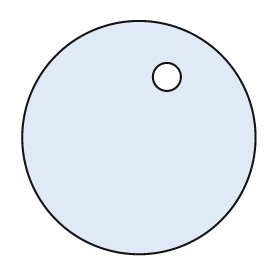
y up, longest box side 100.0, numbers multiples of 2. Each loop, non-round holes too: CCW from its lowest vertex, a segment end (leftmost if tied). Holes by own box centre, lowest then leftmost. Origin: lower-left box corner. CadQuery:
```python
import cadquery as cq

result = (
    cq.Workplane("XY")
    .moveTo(50.0, 50.0)
    .circle(50.0)
    .moveTo(62.0, 76.0)
    .circle(6.0)
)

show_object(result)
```